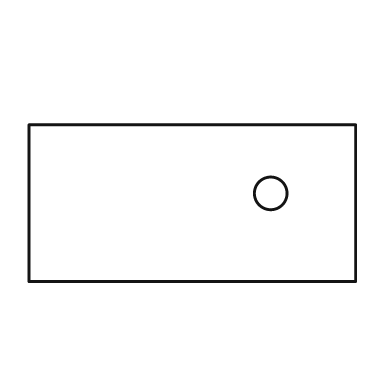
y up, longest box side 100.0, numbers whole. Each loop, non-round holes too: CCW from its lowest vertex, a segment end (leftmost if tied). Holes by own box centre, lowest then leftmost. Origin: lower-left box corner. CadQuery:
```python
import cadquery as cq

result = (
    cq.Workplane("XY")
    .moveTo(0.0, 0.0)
    .lineTo(100.0, 0.0)
    .lineTo(100.0, 48.0)
    .lineTo(0.0, 48.0)
    .close()
    .moveTo(74.0, 27.0)
    .circle(5.0)
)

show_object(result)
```